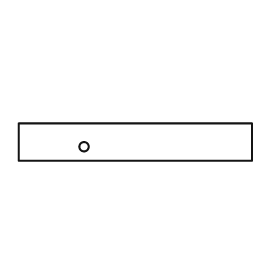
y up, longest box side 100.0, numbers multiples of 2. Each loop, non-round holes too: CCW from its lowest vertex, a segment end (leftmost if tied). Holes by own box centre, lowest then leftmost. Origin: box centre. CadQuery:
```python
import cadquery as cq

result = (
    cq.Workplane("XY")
    .moveTo(-50.0, -8.0)
    .lineTo(50.0, -8.0)
    .lineTo(50.0, 8.0)
    .lineTo(-50.0, 8.0)
    .close()
    .moveTo(-22.0, -2.0)
    .circle(2.0)
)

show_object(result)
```